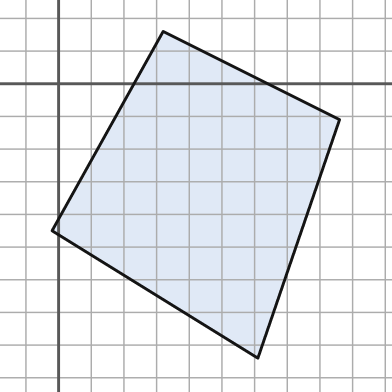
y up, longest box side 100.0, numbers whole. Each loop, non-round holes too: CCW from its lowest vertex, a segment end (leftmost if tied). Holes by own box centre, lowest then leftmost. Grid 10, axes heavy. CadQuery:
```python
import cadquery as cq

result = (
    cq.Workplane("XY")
    .moveTo(61.0, -84.0)
    .lineTo(86.0, -11.0)
    .lineTo(32.0, 16.0)
    .lineTo(-2.0, -45.0)
    .close()
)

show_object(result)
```